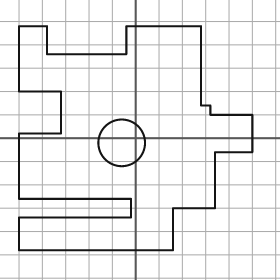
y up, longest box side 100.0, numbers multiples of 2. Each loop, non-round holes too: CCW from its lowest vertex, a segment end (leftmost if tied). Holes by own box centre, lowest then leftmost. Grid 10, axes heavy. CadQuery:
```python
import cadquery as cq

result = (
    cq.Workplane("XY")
    .moveTo(-50.0, -48.0)
    .lineTo(16.0, -48.0)
    .lineTo(16.0, -30.0)
    .lineTo(34.0, -30.0)
    .lineTo(34.0, -6.0)
    .lineTo(50.0, -6.0)
    .lineTo(50.0, 10.0)
    .lineTo(32.0, 10.0)
    .lineTo(32.0, 14.0)
    .lineTo(28.0, 14.0)
    .lineTo(28.0, 48.0)
    .lineTo(-4.0, 48.0)
    .lineTo(-4.0, 36.0)
    .lineTo(-38.0, 36.0)
    .lineTo(-38.0, 48.0)
    .lineTo(-50.0, 48.0)
    .lineTo(-50.0, 20.0)
    .lineTo(-32.0, 20.0)
    .lineTo(-32.0, 2.0)
    .lineTo(-50.0, 2.0)
    .lineTo(-50.0, -26.0)
    .lineTo(-2.0, -26.0)
    .lineTo(-2.0, -34.0)
    .lineTo(-50.0, -34.0)
    .close()
    .moveTo(-6.0, -2.0)
    .circle(10.0)
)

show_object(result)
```